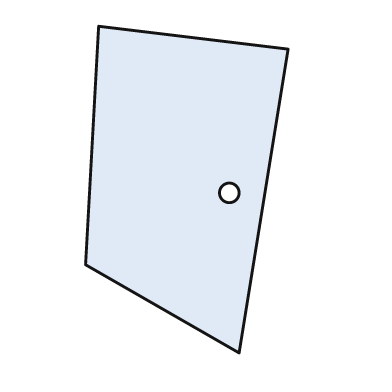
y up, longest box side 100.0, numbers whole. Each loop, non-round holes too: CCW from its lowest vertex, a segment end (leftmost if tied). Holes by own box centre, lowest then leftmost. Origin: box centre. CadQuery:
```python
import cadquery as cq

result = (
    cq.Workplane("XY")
    .moveTo(16.0, -50.0)
    .lineTo(31.0, 43.0)
    .lineTo(-27.0, 50.0)
    .lineTo(-31.0, -23.0)
    .close()
    .moveTo(13.0, -1.0)
    .circle(3.0)
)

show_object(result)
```